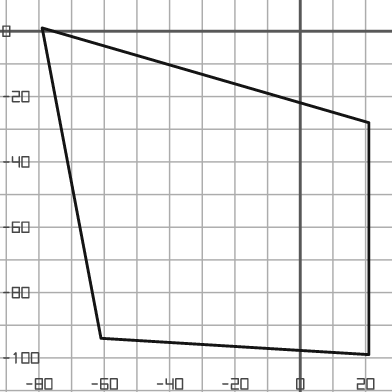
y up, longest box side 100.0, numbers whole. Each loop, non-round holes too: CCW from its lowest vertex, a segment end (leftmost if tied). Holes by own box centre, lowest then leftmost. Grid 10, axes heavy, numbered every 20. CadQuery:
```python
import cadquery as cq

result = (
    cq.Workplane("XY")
    .moveTo(21.0, -99.0)
    .lineTo(21.0, -28.0)
    .lineTo(-79.0, 1.0)
    .lineTo(-61.0, -94.0)
    .close()
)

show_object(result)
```